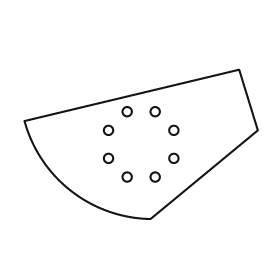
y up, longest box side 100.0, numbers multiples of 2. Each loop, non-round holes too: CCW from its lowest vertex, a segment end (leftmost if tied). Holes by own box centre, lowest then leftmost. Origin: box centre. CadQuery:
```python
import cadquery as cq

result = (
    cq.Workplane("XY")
    .moveTo(4.0, -32.0)
    .lineTo(50.0, 6.0)
    .lineTo(42.0, 32.0)
    .lineTo(-50.0, 10.0)
    .threePointArc((-30.0, -20.0), (4.0, -32.0))
    .close()
    .moveTo(-6.0, -14.0)
    .circle(2.0)
    .moveTo(6.0, -14.0)
    .circle(2.0)
    .moveTo(-14.0, -6.0)
    .circle(2.0)
    .moveTo(14.0, -6.0)
    .circle(2.0)
    .moveTo(-14.0, 6.0)
    .circle(2.0)
    .moveTo(14.0, 6.0)
    .circle(2.0)
    .moveTo(-6.0, 14.0)
    .circle(2.0)
    .moveTo(6.0, 14.0)
    .circle(2.0)
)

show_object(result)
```